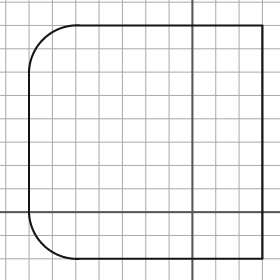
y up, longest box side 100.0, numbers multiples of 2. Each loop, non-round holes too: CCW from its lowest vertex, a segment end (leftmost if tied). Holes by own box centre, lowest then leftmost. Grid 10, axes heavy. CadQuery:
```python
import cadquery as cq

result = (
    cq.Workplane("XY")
    .moveTo(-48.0, -20.0)
    .lineTo(30.0, -20.0)
    .lineTo(30.0, 80.0)
    .lineTo(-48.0, 80.0)
    .threePointArc((-64.0, 74.0), (-70.0, 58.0))
    .lineTo(-70.0, 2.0)
    .threePointArc((-64.0, -14.0), (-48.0, -20.0))
    .close()
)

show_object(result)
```